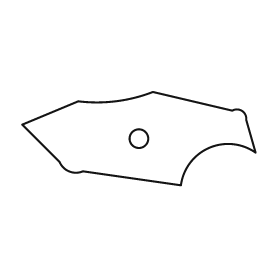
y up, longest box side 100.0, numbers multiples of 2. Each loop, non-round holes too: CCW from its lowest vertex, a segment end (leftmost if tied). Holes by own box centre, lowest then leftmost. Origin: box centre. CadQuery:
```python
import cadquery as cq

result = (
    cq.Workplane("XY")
    .moveTo(18.0, -20.0)
    .threePointArc((30.0, -4.0), (50.0, -6.0))
    .lineTo(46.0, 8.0)
    .threePointArc((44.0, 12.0), (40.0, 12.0))
    .lineTo(6.0, 20.0)
    .threePointArc((-10.0, 16.0), (-26.0, 16.0))
    .lineTo(-50.0, 6.0)
    .lineTo(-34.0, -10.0)
    .threePointArc((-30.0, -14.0), (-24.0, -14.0))
    .close()
    .moveTo(0.0, 0.0)
    .circle(4.0)
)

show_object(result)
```